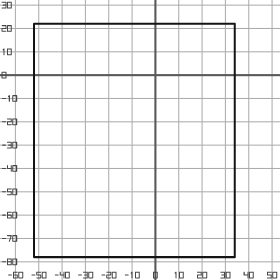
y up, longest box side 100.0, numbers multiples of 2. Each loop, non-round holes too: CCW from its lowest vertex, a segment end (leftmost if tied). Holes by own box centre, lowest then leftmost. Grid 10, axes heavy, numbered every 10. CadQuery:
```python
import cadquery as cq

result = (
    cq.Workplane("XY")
    .moveTo(-52.0, -78.0)
    .lineTo(34.0, -78.0)
    .lineTo(34.0, 22.0)
    .lineTo(-52.0, 22.0)
    .close()
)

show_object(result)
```